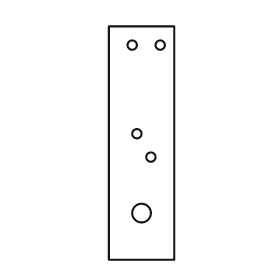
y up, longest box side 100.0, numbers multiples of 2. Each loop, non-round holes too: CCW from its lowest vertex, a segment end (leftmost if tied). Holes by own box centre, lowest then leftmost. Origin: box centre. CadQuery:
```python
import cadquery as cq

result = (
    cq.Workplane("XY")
    .moveTo(-14.0, -50.0)
    .lineTo(14.0, -50.0)
    .lineTo(14.0, 50.0)
    .lineTo(-14.0, 50.0)
    .close()
    .moveTo(0.0, -30.0)
    .circle(4.0)
    .moveTo(4.0, -6.0)
    .circle(2.0)
    .moveTo(-2.0, 4.0)
    .circle(2.0)
    .moveTo(-4.0, 42.0)
    .circle(2.0)
    .moveTo(8.0, 42.0)
    .circle(2.0)
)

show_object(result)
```